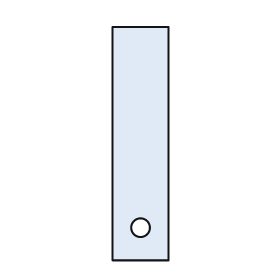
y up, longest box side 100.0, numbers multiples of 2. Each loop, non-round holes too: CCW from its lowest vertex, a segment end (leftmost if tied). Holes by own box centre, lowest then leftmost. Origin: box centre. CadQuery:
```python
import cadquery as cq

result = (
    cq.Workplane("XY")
    .moveTo(-12.0, -50.0)
    .lineTo(12.0, -50.0)
    .lineTo(12.0, 50.0)
    .lineTo(-12.0, 50.0)
    .close()
    .moveTo(0.0, -36.0)
    .circle(4.0)
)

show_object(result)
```